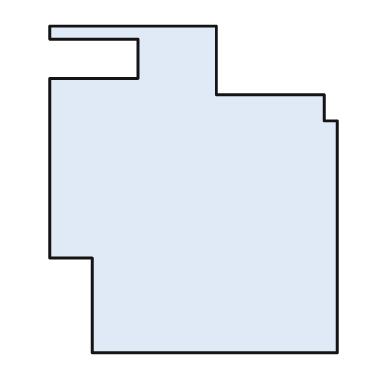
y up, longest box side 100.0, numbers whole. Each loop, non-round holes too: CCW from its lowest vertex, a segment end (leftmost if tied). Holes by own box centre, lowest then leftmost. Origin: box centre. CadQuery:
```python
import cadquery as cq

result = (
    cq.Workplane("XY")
    .moveTo(-31.0, -50.0)
    .lineTo(44.0, -50.0)
    .lineTo(44.0, 21.0)
    .lineTo(40.0, 21.0)
    .lineTo(40.0, 29.0)
    .lineTo(7.0, 29.0)
    .lineTo(7.0, 50.0)
    .lineTo(-44.0, 50.0)
    .lineTo(-44.0, 46.0)
    .lineTo(-17.0, 46.0)
    .lineTo(-17.0, 34.0)
    .lineTo(-44.0, 34.0)
    .lineTo(-44.0, -21.0)
    .lineTo(-31.0, -21.0)
    .close()
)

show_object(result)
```